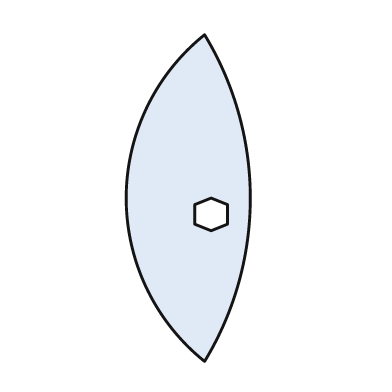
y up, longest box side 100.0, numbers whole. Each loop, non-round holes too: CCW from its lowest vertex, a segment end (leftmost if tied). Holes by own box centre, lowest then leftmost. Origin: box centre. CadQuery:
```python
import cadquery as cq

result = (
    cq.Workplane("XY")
    .moveTo(5.0, -50.0)
    .threePointArc((19.0, 0.0), (5.0, 50.0))
    .threePointArc((-19.0, 0.0), (5.0, -50.0))
    .close()
    .moveTo(7.0, -10.0)
    .lineTo(12.0, -8.0)
    .lineTo(12.0, -2.0)
    .lineTo(7.0, 0.0)
    .lineTo(2.0, -2.0)
    .lineTo(2.0, -8.0)
    .close()
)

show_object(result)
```